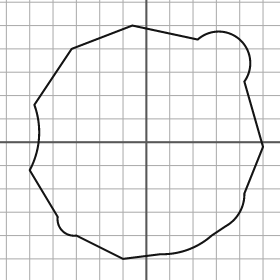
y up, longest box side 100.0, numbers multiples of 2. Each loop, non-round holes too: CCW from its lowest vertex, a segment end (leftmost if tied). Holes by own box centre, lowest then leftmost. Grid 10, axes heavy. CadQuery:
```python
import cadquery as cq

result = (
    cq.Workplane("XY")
    .moveTo(-10.0, -50.0)
    .lineTo(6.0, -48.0)
    .threePointArc((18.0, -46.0), (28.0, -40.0))
    .lineTo(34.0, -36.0)
    .threePointArc((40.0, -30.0), (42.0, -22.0))
    .lineTo(50.0, -2.0)
    .lineTo(42.0, 26.0)
    .threePointArc((40.0, 44.0), (22.0, 44.0))
    .lineTo(-6.0, 50.0)
    .lineTo(-32.0, 40.0)
    .lineTo(-48.0, 16.0)
    .threePointArc((-46.0, 2.0), (-50.0, -12.0))
    .lineTo(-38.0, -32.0)
    .threePointArc((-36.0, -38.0), (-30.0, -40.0))
    .close()
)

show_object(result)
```